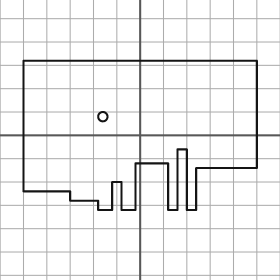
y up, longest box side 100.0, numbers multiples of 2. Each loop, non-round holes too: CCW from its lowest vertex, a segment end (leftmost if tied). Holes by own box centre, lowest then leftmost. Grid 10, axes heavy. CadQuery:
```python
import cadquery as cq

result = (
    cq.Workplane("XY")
    .moveTo(-18.0, -32.0)
    .lineTo(-12.0, -32.0)
    .lineTo(-12.0, -20.0)
    .lineTo(-8.0, -20.0)
    .lineTo(-8.0, -32.0)
    .lineTo(-2.0, -32.0)
    .lineTo(-2.0, -12.0)
    .lineTo(12.0, -12.0)
    .lineTo(12.0, -32.0)
    .lineTo(16.0, -32.0)
    .lineTo(16.0, -6.0)
    .lineTo(20.0, -6.0)
    .lineTo(20.0, -32.0)
    .lineTo(24.0, -32.0)
    .lineTo(24.0, -14.0)
    .lineTo(50.0, -14.0)
    .lineTo(50.0, 32.0)
    .lineTo(-50.0, 32.0)
    .lineTo(-50.0, -24.0)
    .lineTo(-30.0, -24.0)
    .lineTo(-30.0, -28.0)
    .lineTo(-18.0, -28.0)
    .close()
    .moveTo(-16.0, 8.0)
    .circle(2.0)
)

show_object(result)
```